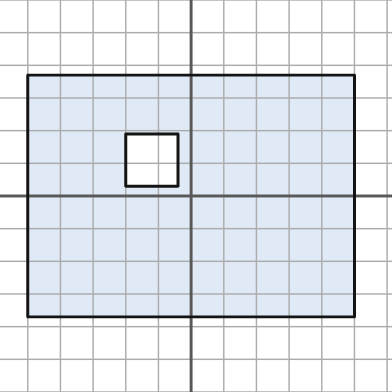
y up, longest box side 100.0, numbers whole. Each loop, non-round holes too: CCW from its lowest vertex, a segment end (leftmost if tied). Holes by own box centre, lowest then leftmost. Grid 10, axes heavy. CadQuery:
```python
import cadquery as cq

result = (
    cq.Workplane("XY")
    .moveTo(-50.0, -37.0)
    .lineTo(50.0, -37.0)
    .lineTo(50.0, 37.0)
    .lineTo(-50.0, 37.0)
    .close()
    .moveTo(-20.0, 3.0)
    .lineTo(-4.0, 3.0)
    .lineTo(-4.0, 19.0)
    .lineTo(-20.0, 19.0)
    .close()
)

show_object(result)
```